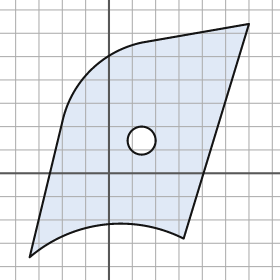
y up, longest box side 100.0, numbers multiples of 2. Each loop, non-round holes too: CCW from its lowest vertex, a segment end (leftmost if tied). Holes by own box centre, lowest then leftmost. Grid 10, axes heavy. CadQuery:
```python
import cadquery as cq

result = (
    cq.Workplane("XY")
    .moveTo(-34.0, -36.0)
    .threePointArc((-2.0, -22.0), (32.0, -28.0))
    .lineTo(60.0, 64.0)
    .lineTo(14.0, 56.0)
    .threePointArc((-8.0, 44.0), (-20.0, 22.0))
    .close()
    .moveTo(14.0, 14.0)
    .circle(6.0)
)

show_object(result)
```